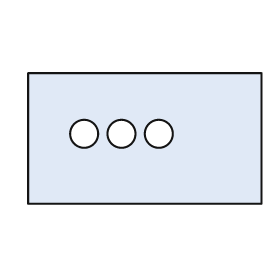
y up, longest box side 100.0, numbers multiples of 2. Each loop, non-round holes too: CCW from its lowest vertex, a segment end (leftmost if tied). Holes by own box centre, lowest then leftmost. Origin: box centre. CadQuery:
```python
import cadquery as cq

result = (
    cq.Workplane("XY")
    .moveTo(-50.0, -28.0)
    .lineTo(50.0, -28.0)
    .lineTo(50.0, 28.0)
    .lineTo(-50.0, 28.0)
    .close()
    .moveTo(-26.0, 2.0)
    .circle(6.0)
    .moveTo(-10.0, 2.0)
    .circle(6.0)
    .moveTo(6.0, 2.0)
    .circle(6.0)
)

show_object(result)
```